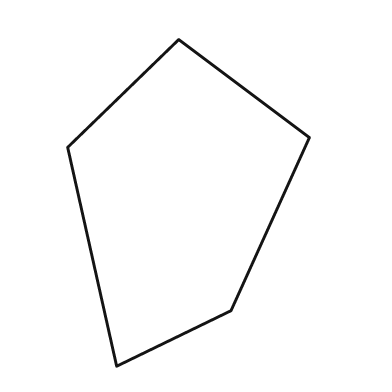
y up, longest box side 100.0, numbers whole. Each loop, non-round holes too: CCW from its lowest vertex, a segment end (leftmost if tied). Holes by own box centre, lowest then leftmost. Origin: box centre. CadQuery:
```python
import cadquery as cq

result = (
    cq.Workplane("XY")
    .moveTo(-22.0, -50.0)
    .lineTo(13.0, -33.0)
    .lineTo(37.0, 20.0)
    .lineTo(-3.0, 50.0)
    .lineTo(-37.0, 17.0)
    .close()
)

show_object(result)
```